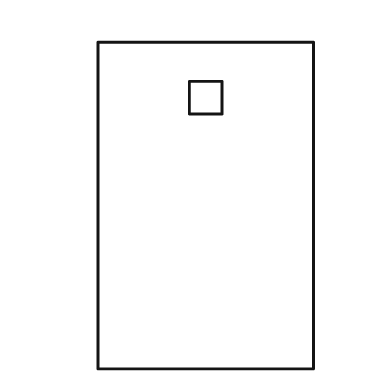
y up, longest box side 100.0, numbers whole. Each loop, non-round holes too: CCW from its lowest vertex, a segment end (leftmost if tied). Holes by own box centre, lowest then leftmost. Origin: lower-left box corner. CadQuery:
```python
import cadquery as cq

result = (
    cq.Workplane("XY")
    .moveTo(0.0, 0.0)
    .lineTo(66.0, 0.0)
    .lineTo(66.0, 100.0)
    .lineTo(0.0, 100.0)
    .close()
    .moveTo(28.0, 78.0)
    .lineTo(38.0, 78.0)
    .lineTo(38.0, 88.0)
    .lineTo(28.0, 88.0)
    .close()
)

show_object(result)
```